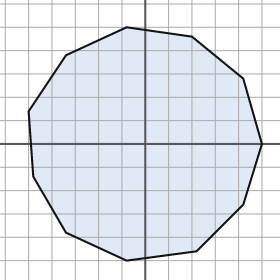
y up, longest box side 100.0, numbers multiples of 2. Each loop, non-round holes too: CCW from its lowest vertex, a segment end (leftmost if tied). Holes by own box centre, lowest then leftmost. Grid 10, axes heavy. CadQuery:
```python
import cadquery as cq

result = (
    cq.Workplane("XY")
    .moveTo(-8.0, -50.0)
    .lineTo(22.0, -46.0)
    .lineTo(42.0, -26.0)
    .lineTo(50.0, 0.0)
    .lineTo(42.0, 28.0)
    .lineTo(20.0, 46.0)
    .lineTo(-8.0, 50.0)
    .lineTo(-34.0, 38.0)
    .lineTo(-50.0, 14.0)
    .lineTo(-48.0, -14.0)
    .lineTo(-34.0, -38.0)
    .close()
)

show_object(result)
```